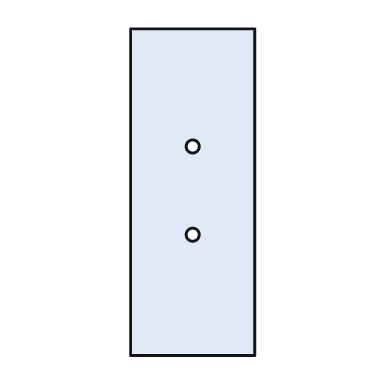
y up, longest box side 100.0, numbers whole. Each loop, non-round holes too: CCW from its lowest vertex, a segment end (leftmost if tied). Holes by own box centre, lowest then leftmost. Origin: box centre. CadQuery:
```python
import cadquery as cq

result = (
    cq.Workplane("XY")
    .moveTo(-19.0, -50.0)
    .lineTo(19.0, -50.0)
    .lineTo(19.0, 50.0)
    .lineTo(-19.0, 50.0)
    .close()
    .moveTo(0.0, -13.0)
    .circle(2.0)
    .moveTo(0.0, 14.0)
    .circle(2.0)
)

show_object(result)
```